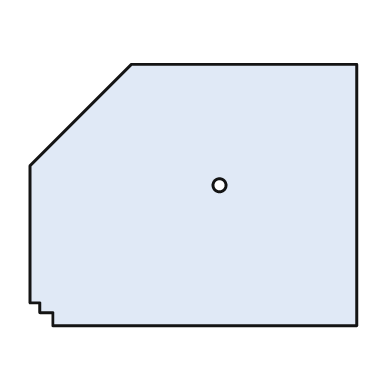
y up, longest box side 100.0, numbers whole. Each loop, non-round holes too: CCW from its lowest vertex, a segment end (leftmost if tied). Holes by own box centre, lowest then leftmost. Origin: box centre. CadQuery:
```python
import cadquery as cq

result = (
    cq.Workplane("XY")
    .moveTo(-43.0, -40.0)
    .lineTo(50.0, -40.0)
    .lineTo(50.0, 40.0)
    .lineTo(-19.0, 40.0)
    .lineTo(-50.0, 9.0)
    .lineTo(-50.0, -33.0)
    .lineTo(-47.0, -33.0)
    .lineTo(-47.0, -36.0)
    .lineTo(-43.0, -36.0)
    .close()
    .moveTo(8.0, 3.0)
    .circle(2.0)
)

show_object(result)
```